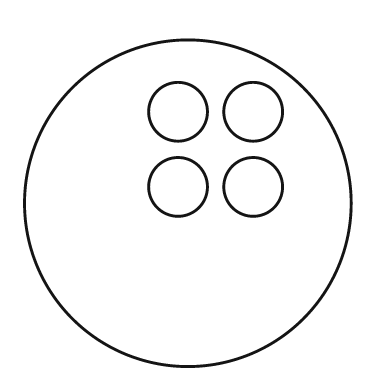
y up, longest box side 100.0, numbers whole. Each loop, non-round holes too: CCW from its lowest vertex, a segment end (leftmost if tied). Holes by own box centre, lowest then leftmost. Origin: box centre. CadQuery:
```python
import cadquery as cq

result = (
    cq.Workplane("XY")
    .moveTo(0.0, 0.0)
    .circle(50.0)
    .moveTo(-3.0, 5.0)
    .circle(9.0)
    .moveTo(20.0, 5.0)
    .circle(9.0)
    .moveTo(-3.0, 28.0)
    .circle(9.0)
    .moveTo(20.0, 28.0)
    .circle(9.0)
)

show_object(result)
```